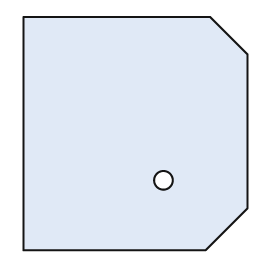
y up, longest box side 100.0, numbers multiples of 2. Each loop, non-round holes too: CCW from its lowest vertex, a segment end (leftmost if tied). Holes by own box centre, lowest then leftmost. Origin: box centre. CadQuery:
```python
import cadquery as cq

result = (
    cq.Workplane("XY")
    .moveTo(-48.0, -50.0)
    .lineTo(30.0, -50.0)
    .lineTo(48.0, -32.0)
    .lineTo(48.0, 34.0)
    .lineTo(32.0, 50.0)
    .lineTo(-48.0, 50.0)
    .close()
    .moveTo(12.0, -20.0)
    .circle(4.0)
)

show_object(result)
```